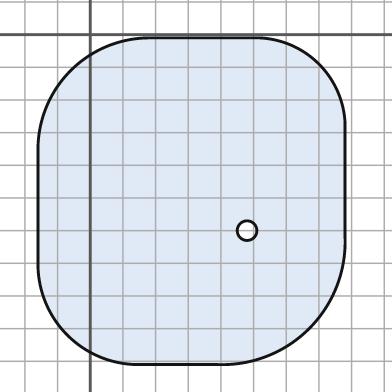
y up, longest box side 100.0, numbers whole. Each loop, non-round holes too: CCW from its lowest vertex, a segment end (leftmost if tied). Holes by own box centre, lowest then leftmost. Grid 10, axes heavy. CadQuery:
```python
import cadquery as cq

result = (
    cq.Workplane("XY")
    .moveTo(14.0, -101.0)
    .lineTo(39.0, -101.0)
    .threePointArc((67.0, -90.0), (78.0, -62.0))
    .lineTo(78.0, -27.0)
    .threePointArc((70.0, -9.0), (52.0, -1.0))
    .lineTo(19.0, -1.0)
    .threePointArc((-6.0, -11.0), (-16.0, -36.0))
    .lineTo(-16.0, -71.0)
    .threePointArc((-7.0, -92.0), (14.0, -101.0))
    .close()
    .moveTo(48.0, -60.0)
    .circle(3.0)
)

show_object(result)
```